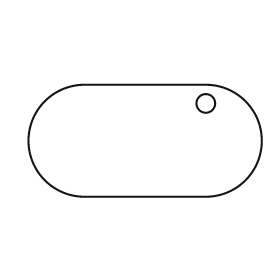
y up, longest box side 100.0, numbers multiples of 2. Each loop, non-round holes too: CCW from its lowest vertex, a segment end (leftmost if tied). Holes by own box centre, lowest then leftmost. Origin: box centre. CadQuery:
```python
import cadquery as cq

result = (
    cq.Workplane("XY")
    .moveTo(-26.0, -24.0)
    .lineTo(26.0, -24.0)
    .threePointArc((50.0, 0.0), (26.0, 24.0))
    .lineTo(-26.0, 24.0)
    .threePointArc((-50.0, 0.0), (-26.0, -24.0))
    .close()
    .moveTo(26.0, 16.0)
    .circle(4.0)
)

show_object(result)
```